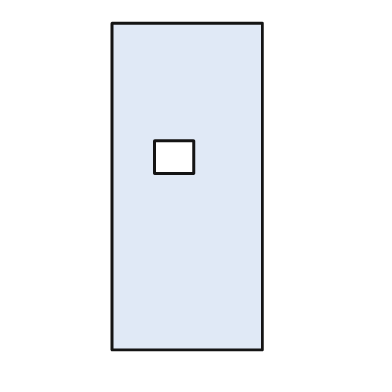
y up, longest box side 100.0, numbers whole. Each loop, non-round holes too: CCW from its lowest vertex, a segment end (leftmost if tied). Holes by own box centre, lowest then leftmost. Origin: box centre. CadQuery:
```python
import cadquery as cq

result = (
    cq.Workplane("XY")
    .moveTo(-23.0, -50.0)
    .lineTo(23.0, -50.0)
    .lineTo(23.0, 50.0)
    .lineTo(-23.0, 50.0)
    .close()
    .moveTo(-10.0, 4.0)
    .lineTo(2.0, 4.0)
    .lineTo(2.0, 14.0)
    .lineTo(-10.0, 14.0)
    .close()
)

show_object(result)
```